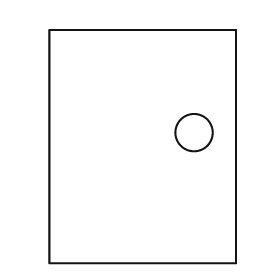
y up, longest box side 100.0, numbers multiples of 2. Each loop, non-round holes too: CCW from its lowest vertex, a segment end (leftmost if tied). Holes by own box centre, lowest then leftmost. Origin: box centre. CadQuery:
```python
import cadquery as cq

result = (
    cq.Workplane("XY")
    .moveTo(-40.0, -50.0)
    .lineTo(40.0, -50.0)
    .lineTo(40.0, 50.0)
    .lineTo(-40.0, 50.0)
    .close()
    .moveTo(22.0, 6.0)
    .circle(8.0)
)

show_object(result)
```